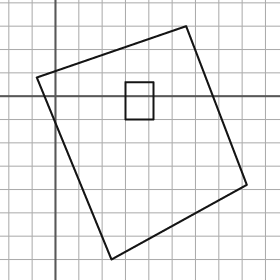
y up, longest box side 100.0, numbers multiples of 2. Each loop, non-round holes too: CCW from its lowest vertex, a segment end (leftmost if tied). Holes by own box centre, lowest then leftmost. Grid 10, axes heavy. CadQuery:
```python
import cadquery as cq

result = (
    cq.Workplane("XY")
    .moveTo(24.0, -70.0)
    .lineTo(82.0, -38.0)
    .lineTo(56.0, 30.0)
    .lineTo(-8.0, 8.0)
    .close()
    .moveTo(30.0, -10.0)
    .lineTo(42.0, -10.0)
    .lineTo(42.0, 6.0)
    .lineTo(30.0, 6.0)
    .close()
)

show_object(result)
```